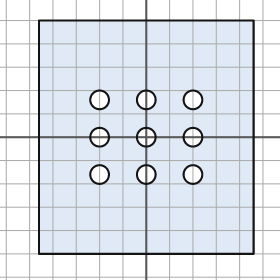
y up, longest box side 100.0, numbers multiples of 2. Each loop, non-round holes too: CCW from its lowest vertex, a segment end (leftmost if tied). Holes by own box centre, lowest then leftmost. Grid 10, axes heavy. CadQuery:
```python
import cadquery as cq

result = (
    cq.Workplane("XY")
    .moveTo(-46.0, -50.0)
    .lineTo(46.0, -50.0)
    .lineTo(46.0, 50.0)
    .lineTo(-46.0, 50.0)
    .close()
    .moveTo(-20.0, -16.0)
    .circle(4.0)
    .moveTo(0.0, -16.0)
    .circle(4.0)
    .moveTo(20.0, -16.0)
    .circle(4.0)
    .moveTo(-20.0, 0.0)
    .circle(4.0)
    .moveTo(0.0, 0.0)
    .circle(4.0)
    .moveTo(20.0, 0.0)
    .circle(4.0)
    .moveTo(-20.0, 16.0)
    .circle(4.0)
    .moveTo(0.0, 16.0)
    .circle(4.0)
    .moveTo(20.0, 16.0)
    .circle(4.0)
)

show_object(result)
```